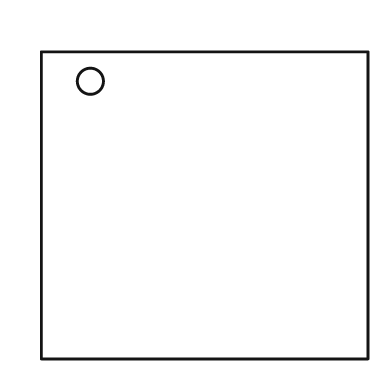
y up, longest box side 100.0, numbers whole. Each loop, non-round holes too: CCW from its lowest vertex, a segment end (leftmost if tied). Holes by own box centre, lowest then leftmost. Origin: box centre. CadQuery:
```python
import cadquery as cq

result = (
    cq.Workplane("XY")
    .moveTo(-50.0, -47.0)
    .lineTo(50.0, -47.0)
    .lineTo(50.0, 47.0)
    .lineTo(-50.0, 47.0)
    .close()
    .moveTo(-35.0, 38.0)
    .circle(4.0)
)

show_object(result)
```